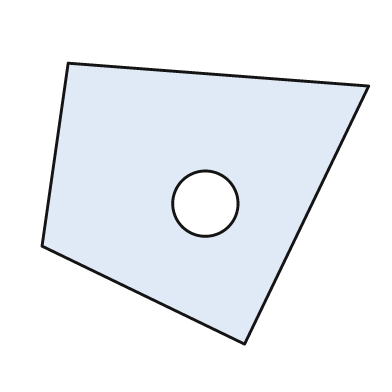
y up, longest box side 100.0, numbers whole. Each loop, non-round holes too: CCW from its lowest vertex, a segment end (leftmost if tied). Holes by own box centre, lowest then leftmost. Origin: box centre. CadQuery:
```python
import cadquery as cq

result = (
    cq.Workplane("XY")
    .moveTo(12.0, -43.0)
    .lineTo(50.0, 36.0)
    .lineTo(-42.0, 43.0)
    .lineTo(-50.0, -13.0)
    .close()
    .moveTo(0.0, 0.0)
    .circle(10.0)
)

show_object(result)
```